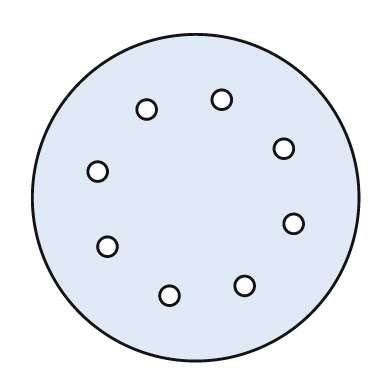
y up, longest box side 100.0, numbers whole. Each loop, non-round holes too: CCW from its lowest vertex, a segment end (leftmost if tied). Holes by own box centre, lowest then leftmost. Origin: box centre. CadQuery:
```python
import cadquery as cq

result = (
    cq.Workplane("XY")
    .moveTo(0.0, 0.0)
    .circle(50.0)
    .moveTo(-8.0, -30.0)
    .circle(3.0)
    .moveTo(15.0, -27.0)
    .circle(3.0)
    .moveTo(-27.0, -15.0)
    .circle(3.0)
    .moveTo(30.0, -8.0)
    .circle(3.0)
    .moveTo(-30.0, 8.0)
    .circle(3.0)
    .moveTo(27.0, 15.0)
    .circle(3.0)
    .moveTo(-15.0, 27.0)
    .circle(3.0)
    .moveTo(8.0, 30.0)
    .circle(3.0)
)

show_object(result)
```